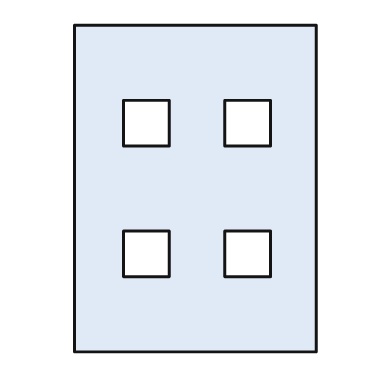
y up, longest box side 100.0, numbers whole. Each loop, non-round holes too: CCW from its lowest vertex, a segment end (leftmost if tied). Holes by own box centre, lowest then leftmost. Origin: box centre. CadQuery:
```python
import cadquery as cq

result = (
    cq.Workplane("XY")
    .moveTo(-37.0, -50.0)
    .lineTo(37.0, -50.0)
    .lineTo(37.0, 50.0)
    .lineTo(-37.0, 50.0)
    .close()
    .moveTo(-22.0, -27.0)
    .lineTo(-8.0, -27.0)
    .lineTo(-8.0, -13.0)
    .lineTo(-22.0, -13.0)
    .close()
    .moveTo(9.0, -27.0)
    .lineTo(23.0, -27.0)
    .lineTo(23.0, -13.0)
    .lineTo(9.0, -13.0)
    .close()
    .moveTo(-22.0, 13.0)
    .lineTo(-8.0, 13.0)
    .lineTo(-8.0, 27.0)
    .lineTo(-22.0, 27.0)
    .close()
    .moveTo(9.0, 13.0)
    .lineTo(23.0, 13.0)
    .lineTo(23.0, 27.0)
    .lineTo(9.0, 27.0)
    .close()
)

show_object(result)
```